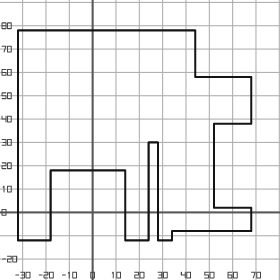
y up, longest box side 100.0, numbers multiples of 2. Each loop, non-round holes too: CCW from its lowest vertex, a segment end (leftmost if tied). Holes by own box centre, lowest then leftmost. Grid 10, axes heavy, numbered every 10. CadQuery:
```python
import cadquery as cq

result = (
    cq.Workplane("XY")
    .moveTo(-32.0, -12.0)
    .lineTo(-18.0, -12.0)
    .lineTo(-18.0, 18.0)
    .lineTo(14.0, 18.0)
    .lineTo(14.0, -12.0)
    .lineTo(24.0, -12.0)
    .lineTo(24.0, 30.0)
    .lineTo(28.0, 30.0)
    .lineTo(28.0, -12.0)
    .lineTo(34.0, -12.0)
    .lineTo(34.0, -8.0)
    .lineTo(68.0, -8.0)
    .lineTo(68.0, 2.0)
    .lineTo(52.0, 2.0)
    .lineTo(52.0, 38.0)
    .lineTo(68.0, 38.0)
    .lineTo(68.0, 58.0)
    .lineTo(44.0, 58.0)
    .lineTo(44.0, 78.0)
    .lineTo(-32.0, 78.0)
    .close()
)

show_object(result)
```